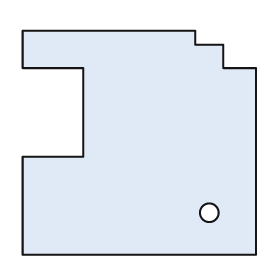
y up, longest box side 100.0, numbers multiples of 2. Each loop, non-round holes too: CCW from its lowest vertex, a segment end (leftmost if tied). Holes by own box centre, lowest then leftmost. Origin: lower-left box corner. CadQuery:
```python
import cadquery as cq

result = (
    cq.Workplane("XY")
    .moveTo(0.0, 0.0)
    .lineTo(100.0, 0.0)
    .lineTo(100.0, 80.0)
    .lineTo(86.0, 80.0)
    .lineTo(86.0, 90.0)
    .lineTo(74.0, 90.0)
    .lineTo(74.0, 96.0)
    .lineTo(0.0, 96.0)
    .lineTo(0.0, 80.0)
    .lineTo(26.0, 80.0)
    .lineTo(26.0, 42.0)
    .lineTo(0.0, 42.0)
    .close()
    .moveTo(80.0, 18.0)
    .circle(4.0)
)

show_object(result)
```